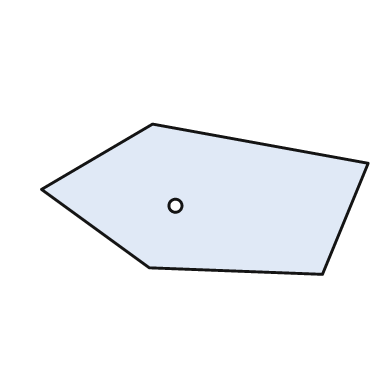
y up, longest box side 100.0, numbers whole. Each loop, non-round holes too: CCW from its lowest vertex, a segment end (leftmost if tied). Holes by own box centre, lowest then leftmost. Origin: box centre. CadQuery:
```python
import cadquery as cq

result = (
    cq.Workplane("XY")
    .moveTo(36.0, -23.0)
    .lineTo(50.0, 11.0)
    .lineTo(-16.0, 23.0)
    .lineTo(-50.0, 3.0)
    .lineTo(-17.0, -21.0)
    .close()
    .moveTo(-9.0, -2.0)
    .circle(2.0)
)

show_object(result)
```